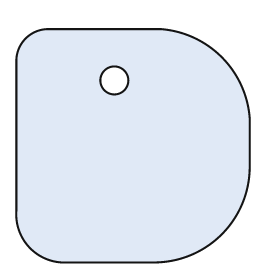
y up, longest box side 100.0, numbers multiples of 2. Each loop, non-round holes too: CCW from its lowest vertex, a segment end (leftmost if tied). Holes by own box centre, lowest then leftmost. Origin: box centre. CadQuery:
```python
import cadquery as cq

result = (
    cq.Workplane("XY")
    .moveTo(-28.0, -50.0)
    .lineTo(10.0, -50.0)
    .threePointArc((38.0, -38.0), (50.0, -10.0))
    .lineTo(50.0, 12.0)
    .threePointArc((38.0, 38.0), (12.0, 50.0))
    .lineTo(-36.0, 50.0)
    .threePointArc((-46.0, 46.0), (-50.0, 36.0))
    .lineTo(-50.0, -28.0)
    .threePointArc((-44.0, -44.0), (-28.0, -50.0))
    .close()
    .moveTo(-8.0, 28.0)
    .circle(6.0)
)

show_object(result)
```